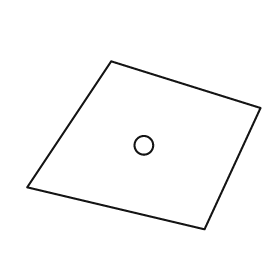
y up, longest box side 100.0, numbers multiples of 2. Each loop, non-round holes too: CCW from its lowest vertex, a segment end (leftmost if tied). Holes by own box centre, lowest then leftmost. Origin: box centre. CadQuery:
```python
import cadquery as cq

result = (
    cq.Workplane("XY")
    .moveTo(26.0, -36.0)
    .lineTo(50.0, 16.0)
    .lineTo(-14.0, 36.0)
    .lineTo(-50.0, -18.0)
    .close()
    .moveTo(0.0, 0.0)
    .circle(4.0)
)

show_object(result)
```